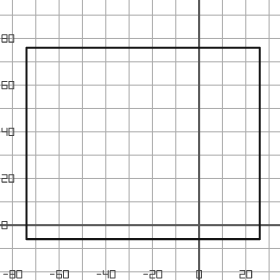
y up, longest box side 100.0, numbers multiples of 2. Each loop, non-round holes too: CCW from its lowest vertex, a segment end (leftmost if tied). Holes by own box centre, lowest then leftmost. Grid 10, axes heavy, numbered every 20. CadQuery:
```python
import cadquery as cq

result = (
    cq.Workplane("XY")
    .moveTo(-74.0, -6.0)
    .lineTo(26.0, -6.0)
    .lineTo(26.0, 76.0)
    .lineTo(-74.0, 76.0)
    .close()
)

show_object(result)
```